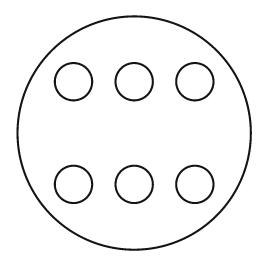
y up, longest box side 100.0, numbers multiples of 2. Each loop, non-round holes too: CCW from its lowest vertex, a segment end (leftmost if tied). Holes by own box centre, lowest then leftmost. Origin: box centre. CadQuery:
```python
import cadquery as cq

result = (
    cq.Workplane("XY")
    .moveTo(0.0, 0.0)
    .circle(50.0)
    .moveTo(-26.0, -22.0)
    .circle(8.0)
    .moveTo(0.0, -22.0)
    .circle(8.0)
    .moveTo(26.0, -22.0)
    .circle(8.0)
    .moveTo(-26.0, 22.0)
    .circle(8.0)
    .moveTo(0.0, 22.0)
    .circle(8.0)
    .moveTo(26.0, 22.0)
    .circle(8.0)
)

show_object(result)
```